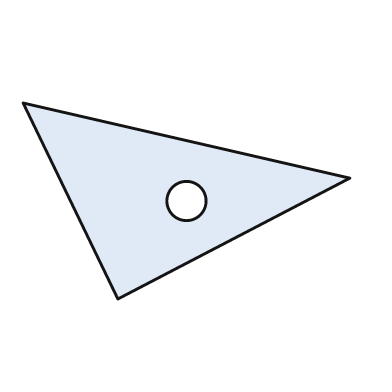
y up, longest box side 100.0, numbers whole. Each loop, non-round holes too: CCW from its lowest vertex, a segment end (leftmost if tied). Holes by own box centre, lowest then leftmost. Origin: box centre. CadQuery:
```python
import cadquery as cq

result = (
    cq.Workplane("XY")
    .moveTo(-21.0, -30.0)
    .lineTo(50.0, 7.0)
    .lineTo(-50.0, 30.0)
    .close()
    .moveTo(0.0, 0.0)
    .circle(6.0)
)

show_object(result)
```